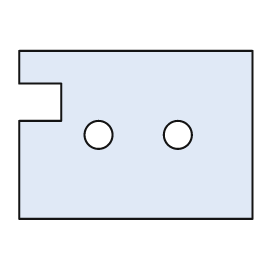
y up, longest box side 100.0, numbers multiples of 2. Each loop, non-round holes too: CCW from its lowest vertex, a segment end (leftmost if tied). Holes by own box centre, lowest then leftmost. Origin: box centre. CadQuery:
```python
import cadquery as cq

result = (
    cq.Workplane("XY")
    .moveTo(-50.0, -36.0)
    .lineTo(50.0, -36.0)
    .lineTo(50.0, 36.0)
    .lineTo(-50.0, 36.0)
    .lineTo(-50.0, 22.0)
    .lineTo(-32.0, 22.0)
    .lineTo(-32.0, 6.0)
    .lineTo(-50.0, 6.0)
    .close()
    .moveTo(-16.0, 0.0)
    .circle(6.0)
    .moveTo(18.0, 0.0)
    .circle(6.0)
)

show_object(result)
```